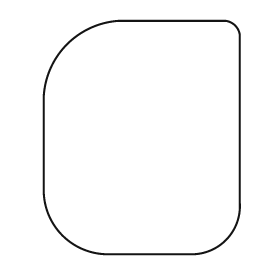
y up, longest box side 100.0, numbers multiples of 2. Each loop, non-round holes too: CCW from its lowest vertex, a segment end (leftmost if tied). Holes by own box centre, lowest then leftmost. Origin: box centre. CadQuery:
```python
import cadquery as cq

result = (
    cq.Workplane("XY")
    .moveTo(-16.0, -50.0)
    .lineTo(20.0, -50.0)
    .threePointArc((36.0, -44.0), (42.0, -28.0))
    .lineTo(42.0, 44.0)
    .threePointArc((40.0, 48.0), (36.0, 50.0))
    .lineTo(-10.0, 50.0)
    .threePointArc((-32.0, 40.0), (-42.0, 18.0))
    .lineTo(-42.0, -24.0)
    .threePointArc((-34.0, -42.0), (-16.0, -50.0))
    .close()
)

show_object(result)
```